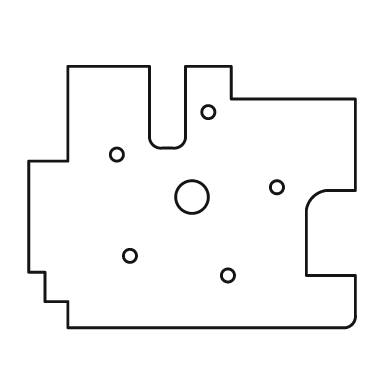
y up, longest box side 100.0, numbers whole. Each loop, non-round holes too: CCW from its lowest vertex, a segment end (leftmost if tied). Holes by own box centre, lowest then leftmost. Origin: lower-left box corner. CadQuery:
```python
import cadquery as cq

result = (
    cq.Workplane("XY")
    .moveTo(12.0, 0.0)
    .lineTo(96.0, 0.0)
    .threePointArc((99.0, 1.0), (100.0, 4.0))
    .lineTo(100.0, 16.0)
    .lineTo(85.0, 16.0)
    .lineTo(85.0, 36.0)
    .threePointArc((87.0, 40.0), (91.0, 42.0))
    .lineTo(100.0, 42.0)
    .lineTo(100.0, 70.0)
    .lineTo(62.0, 70.0)
    .lineTo(62.0, 80.0)
    .lineTo(48.0, 80.0)
    .lineTo(48.0, 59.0)
    .threePointArc((47.0, 56.0), (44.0, 55.0))
    .lineTo(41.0, 55.0)
    .threePointArc((38.0, 56.0), (37.0, 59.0))
    .lineTo(37.0, 80.0)
    .lineTo(12.0, 80.0)
    .lineTo(12.0, 51.0)
    .lineTo(0.0, 51.0)
    .lineTo(0.0, 17.0)
    .lineTo(5.0, 17.0)
    .lineTo(5.0, 8.0)
    .lineTo(12.0, 8.0)
    .close()
    .moveTo(61.0, 16.0)
    .circle(2.0)
    .moveTo(31.0, 22.0)
    .circle(2.0)
    .moveTo(50.0, 40.0)
    .circle(5.0)
    .moveTo(76.0, 43.0)
    .circle(2.0)
    .moveTo(27.0, 53.0)
    .circle(2.0)
    .moveTo(55.0, 66.0)
    .circle(2.0)
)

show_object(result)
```